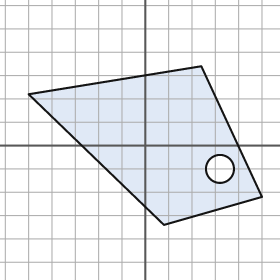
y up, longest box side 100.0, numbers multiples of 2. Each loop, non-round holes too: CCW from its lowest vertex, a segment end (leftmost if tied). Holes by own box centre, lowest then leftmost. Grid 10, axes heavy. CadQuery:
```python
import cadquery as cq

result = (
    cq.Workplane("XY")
    .moveTo(8.0, -34.0)
    .lineTo(50.0, -22.0)
    .lineTo(24.0, 34.0)
    .lineTo(-50.0, 22.0)
    .close()
    .moveTo(32.0, -10.0)
    .circle(6.0)
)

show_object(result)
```